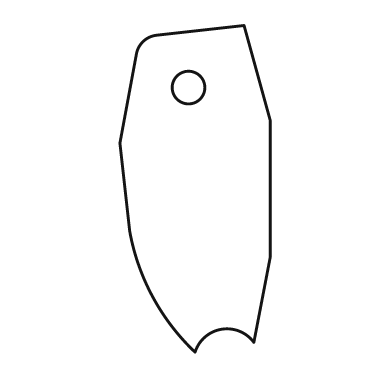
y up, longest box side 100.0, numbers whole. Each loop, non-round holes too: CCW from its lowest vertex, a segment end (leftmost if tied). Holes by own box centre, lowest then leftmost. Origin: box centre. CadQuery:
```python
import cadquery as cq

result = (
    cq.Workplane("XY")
    .moveTo(0.0, -50.0)
    .threePointArc((8.0, -43.0), (18.0, -47.0))
    .lineTo(23.0, -21.0)
    .lineTo(23.0, 21.0)
    .lineTo(15.0, 50.0)
    .lineTo(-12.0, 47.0)
    .threePointArc((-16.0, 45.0), (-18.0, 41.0))
    .lineTo(-23.0, 14.0)
    .lineTo(-20.0, -13.0)
    .threePointArc((-13.0, -33.0), (0.0, -50.0))
    .close()
    .moveTo(-2.0, 31.0)
    .circle(5.0)
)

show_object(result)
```